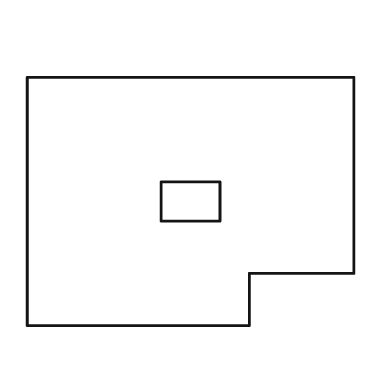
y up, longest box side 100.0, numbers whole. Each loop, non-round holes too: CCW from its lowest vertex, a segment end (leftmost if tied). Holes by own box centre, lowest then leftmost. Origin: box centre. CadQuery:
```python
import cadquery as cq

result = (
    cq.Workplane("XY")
    .moveTo(-50.0, -38.0)
    .lineTo(18.0, -38.0)
    .lineTo(18.0, -22.0)
    .lineTo(50.0, -22.0)
    .lineTo(50.0, 38.0)
    .lineTo(-50.0, 38.0)
    .close()
    .moveTo(-9.0, -6.0)
    .lineTo(9.0, -6.0)
    .lineTo(9.0, 6.0)
    .lineTo(-9.0, 6.0)
    .close()
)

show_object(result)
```